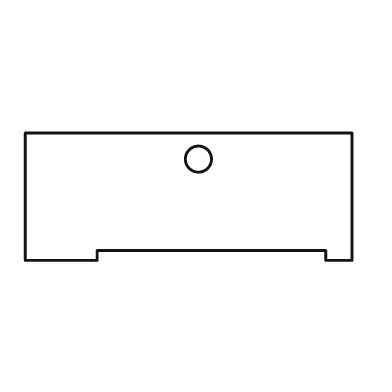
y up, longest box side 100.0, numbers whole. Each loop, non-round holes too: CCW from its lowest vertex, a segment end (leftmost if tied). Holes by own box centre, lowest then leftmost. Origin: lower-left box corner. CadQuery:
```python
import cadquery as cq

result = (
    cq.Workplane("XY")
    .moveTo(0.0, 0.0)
    .lineTo(22.0, 0.0)
    .lineTo(22.0, 3.0)
    .lineTo(92.0, 3.0)
    .lineTo(92.0, 0.0)
    .lineTo(100.0, 0.0)
    .lineTo(100.0, 39.0)
    .lineTo(0.0, 39.0)
    .close()
    .moveTo(53.0, 31.0)
    .circle(4.0)
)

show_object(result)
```